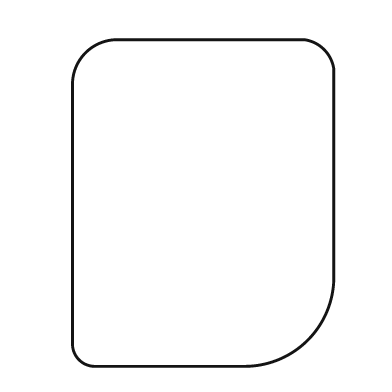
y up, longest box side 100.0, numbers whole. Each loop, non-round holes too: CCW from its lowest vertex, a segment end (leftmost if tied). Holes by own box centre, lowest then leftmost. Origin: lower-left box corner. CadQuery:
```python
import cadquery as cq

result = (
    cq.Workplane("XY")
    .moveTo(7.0, 0.0)
    .lineTo(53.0, 0.0)
    .threePointArc((72.0, 8.0), (80.0, 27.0))
    .lineTo(80.0, 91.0)
    .threePointArc((77.0, 97.0), (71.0, 100.0))
    .lineTo(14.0, 100.0)
    .threePointArc((4.0, 96.0), (0.0, 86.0))
    .lineTo(0.0, 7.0)
    .threePointArc((2.0, 2.0), (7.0, 0.0))
    .close()
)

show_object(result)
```